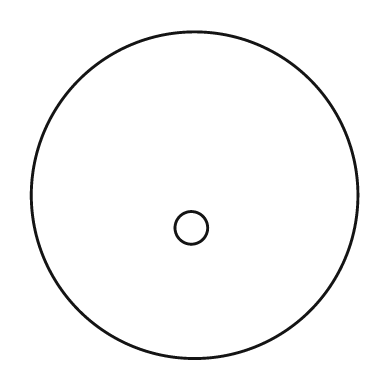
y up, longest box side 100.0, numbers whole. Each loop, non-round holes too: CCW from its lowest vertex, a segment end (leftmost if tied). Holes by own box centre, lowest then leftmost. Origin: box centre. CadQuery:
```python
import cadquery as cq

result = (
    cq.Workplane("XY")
    .moveTo(0.0, 0.0)
    .circle(50.0)
    .moveTo(-1.0, -10.0)
    .circle(5.0)
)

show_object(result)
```